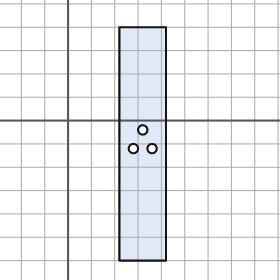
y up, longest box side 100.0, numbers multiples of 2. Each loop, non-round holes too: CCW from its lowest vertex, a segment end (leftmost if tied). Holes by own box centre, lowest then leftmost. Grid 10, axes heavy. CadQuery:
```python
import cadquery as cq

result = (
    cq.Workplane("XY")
    .moveTo(22.0, -60.0)
    .lineTo(42.0, -60.0)
    .lineTo(42.0, 40.0)
    .lineTo(22.0, 40.0)
    .close()
    .moveTo(28.0, -12.0)
    .circle(2.0)
    .moveTo(36.0, -12.0)
    .circle(2.0)
    .moveTo(32.0, -4.0)
    .circle(2.0)
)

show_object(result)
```